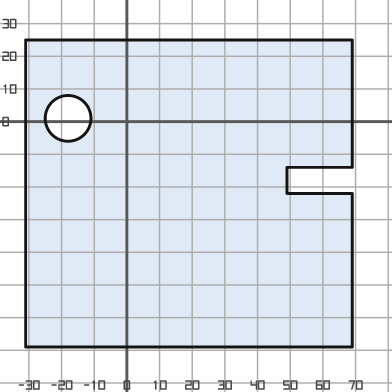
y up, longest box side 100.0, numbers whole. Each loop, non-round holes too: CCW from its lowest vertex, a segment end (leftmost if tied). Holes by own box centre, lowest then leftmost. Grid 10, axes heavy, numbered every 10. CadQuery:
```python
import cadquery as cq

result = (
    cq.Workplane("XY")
    .moveTo(-31.0, -69.0)
    .lineTo(69.0, -69.0)
    .lineTo(69.0, -22.0)
    .lineTo(49.0, -22.0)
    .lineTo(49.0, -14.0)
    .lineTo(69.0, -14.0)
    .lineTo(69.0, 25.0)
    .lineTo(-31.0, 25.0)
    .close()
    .moveTo(-18.0, 1.0)
    .circle(7.0)
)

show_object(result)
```